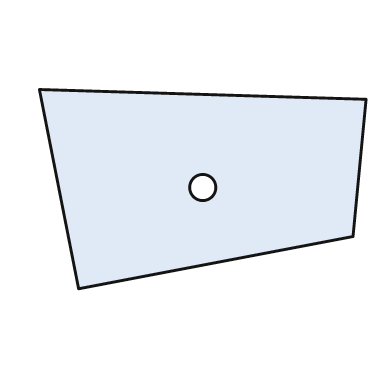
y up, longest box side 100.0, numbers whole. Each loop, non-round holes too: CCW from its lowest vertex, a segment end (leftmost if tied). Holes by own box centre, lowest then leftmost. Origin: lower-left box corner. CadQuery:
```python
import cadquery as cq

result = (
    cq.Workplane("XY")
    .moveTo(12.0, 0.0)
    .lineTo(96.0, 16.0)
    .lineTo(100.0, 58.0)
    .lineTo(0.0, 61.0)
    .close()
    .moveTo(50.0, 31.0)
    .circle(4.0)
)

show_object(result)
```